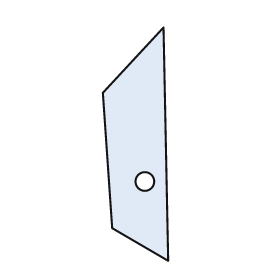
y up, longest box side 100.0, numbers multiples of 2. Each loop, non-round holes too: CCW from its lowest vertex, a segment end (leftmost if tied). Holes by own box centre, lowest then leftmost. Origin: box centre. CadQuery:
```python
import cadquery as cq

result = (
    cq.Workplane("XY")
    .moveTo(14.0, -50.0)
    .lineTo(12.0, 50.0)
    .lineTo(-14.0, 22.0)
    .lineTo(-10.0, -36.0)
    .close()
    .moveTo(4.0, -16.0)
    .circle(4.0)
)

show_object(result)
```